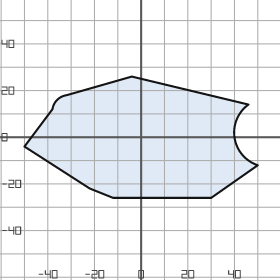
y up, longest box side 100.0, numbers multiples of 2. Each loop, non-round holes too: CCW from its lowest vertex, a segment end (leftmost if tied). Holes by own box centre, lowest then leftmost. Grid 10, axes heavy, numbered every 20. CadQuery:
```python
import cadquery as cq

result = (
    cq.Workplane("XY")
    .moveTo(-12.0, -26.0)
    .lineTo(30.0, -26.0)
    .lineTo(50.0, -12.0)
    .threePointArc((40.0, 0.0), (46.0, 14.0))
    .lineTo(-4.0, 26.0)
    .lineTo(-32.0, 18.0)
    .threePointArc((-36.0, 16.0), (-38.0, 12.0))
    .lineTo(-50.0, -4.0)
    .lineTo(-22.0, -22.0)
    .close()
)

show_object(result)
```